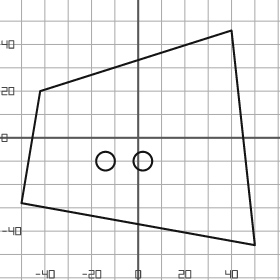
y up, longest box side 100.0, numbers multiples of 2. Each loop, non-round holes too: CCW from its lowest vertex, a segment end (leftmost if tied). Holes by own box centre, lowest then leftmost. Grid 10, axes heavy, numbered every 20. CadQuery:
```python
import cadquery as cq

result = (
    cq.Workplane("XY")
    .moveTo(50.0, -46.0)
    .lineTo(40.0, 46.0)
    .lineTo(-42.0, 20.0)
    .lineTo(-50.0, -28.0)
    .close()
    .moveTo(-14.0, -10.0)
    .circle(4.0)
    .moveTo(2.0, -10.0)
    .circle(4.0)
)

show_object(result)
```